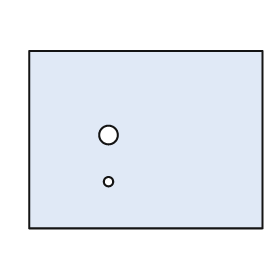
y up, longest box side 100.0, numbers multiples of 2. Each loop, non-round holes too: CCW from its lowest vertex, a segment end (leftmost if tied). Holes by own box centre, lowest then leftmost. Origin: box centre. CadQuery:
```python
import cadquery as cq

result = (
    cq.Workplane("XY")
    .moveTo(-50.0, -38.0)
    .lineTo(50.0, -38.0)
    .lineTo(50.0, 38.0)
    .lineTo(-50.0, 38.0)
    .close()
    .moveTo(-16.0, -18.0)
    .circle(2.0)
    .moveTo(-16.0, 2.0)
    .circle(4.0)
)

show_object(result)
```